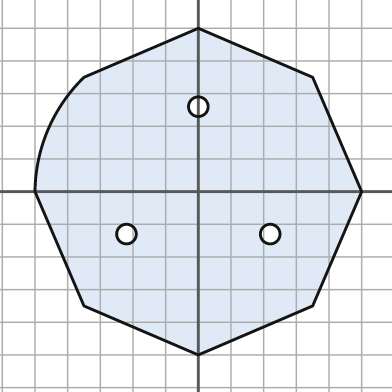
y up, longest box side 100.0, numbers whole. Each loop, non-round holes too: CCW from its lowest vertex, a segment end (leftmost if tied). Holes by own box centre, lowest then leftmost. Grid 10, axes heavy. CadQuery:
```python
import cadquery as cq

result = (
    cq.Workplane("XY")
    .moveTo(0.0, -50.0)
    .lineTo(35.0, -35.0)
    .lineTo(50.0, 0.0)
    .lineTo(35.0, 35.0)
    .lineTo(0.0, 50.0)
    .lineTo(-35.0, 35.0)
    .threePointArc((-46.0, 19.0), (-50.0, 0.0))
    .lineTo(-35.0, -35.0)
    .close()
    .moveTo(-22.0, -13.0)
    .circle(3.0)
    .moveTo(22.0, -13.0)
    .circle(3.0)
    .moveTo(0.0, 26.0)
    .circle(3.0)
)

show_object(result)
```